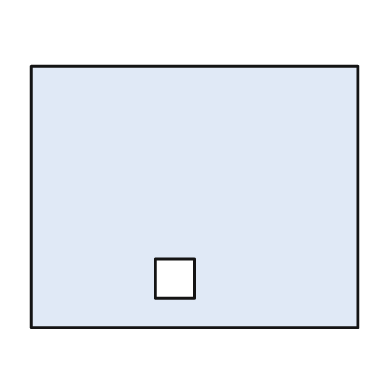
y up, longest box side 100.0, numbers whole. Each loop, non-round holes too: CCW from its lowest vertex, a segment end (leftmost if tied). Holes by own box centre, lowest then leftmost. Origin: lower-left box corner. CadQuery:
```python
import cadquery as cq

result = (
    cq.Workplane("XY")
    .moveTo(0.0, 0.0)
    .lineTo(100.0, 0.0)
    .lineTo(100.0, 80.0)
    .lineTo(0.0, 80.0)
    .close()
    .moveTo(38.0, 9.0)
    .lineTo(50.0, 9.0)
    .lineTo(50.0, 21.0)
    .lineTo(38.0, 21.0)
    .close()
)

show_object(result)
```